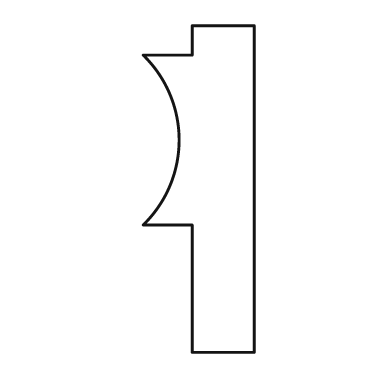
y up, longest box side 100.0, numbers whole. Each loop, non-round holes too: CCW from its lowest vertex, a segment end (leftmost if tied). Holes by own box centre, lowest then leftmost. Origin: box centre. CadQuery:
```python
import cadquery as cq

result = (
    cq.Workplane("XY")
    .moveTo(-2.0, -50.0)
    .lineTo(17.0, -50.0)
    .lineTo(17.0, 50.0)
    .lineTo(-2.0, 50.0)
    .lineTo(-2.0, 41.0)
    .lineTo(-17.0, 41.0)
    .threePointArc((-6.0, 15.0), (-17.0, -11.0))
    .lineTo(-2.0, -11.0)
    .close()
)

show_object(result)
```